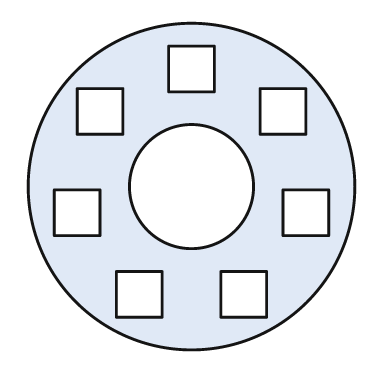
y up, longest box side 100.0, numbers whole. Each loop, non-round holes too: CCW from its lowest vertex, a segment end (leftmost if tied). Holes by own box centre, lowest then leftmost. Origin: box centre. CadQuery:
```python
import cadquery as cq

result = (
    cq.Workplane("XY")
    .moveTo(0.0, 0.0)
    .circle(50.0)
    .moveTo(-23.0, -40.0)
    .lineTo(-9.0, -40.0)
    .lineTo(-9.0, -26.0)
    .lineTo(-23.0, -26.0)
    .close()
    .moveTo(9.0, -40.0)
    .lineTo(23.0, -40.0)
    .lineTo(23.0, -26.0)
    .lineTo(9.0, -26.0)
    .close()
    .moveTo(-42.0, -15.0)
    .lineTo(-28.0, -15.0)
    .lineTo(-28.0, -1.0)
    .lineTo(-42.0, -1.0)
    .close()
    .moveTo(28.0, -15.0)
    .lineTo(42.0, -15.0)
    .lineTo(42.0, -1.0)
    .lineTo(28.0, -1.0)
    .close()
    .moveTo(0.0, 0.0)
    .circle(19.0)
    .moveTo(-35.0, 16.0)
    .lineTo(-21.0, 16.0)
    .lineTo(-21.0, 30.0)
    .lineTo(-35.0, 30.0)
    .close()
    .moveTo(21.0, 16.0)
    .lineTo(35.0, 16.0)
    .lineTo(35.0, 30.0)
    .lineTo(21.0, 30.0)
    .close()
    .moveTo(-7.0, 29.0)
    .lineTo(7.0, 29.0)
    .lineTo(7.0, 43.0)
    .lineTo(-7.0, 43.0)
    .close()
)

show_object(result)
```